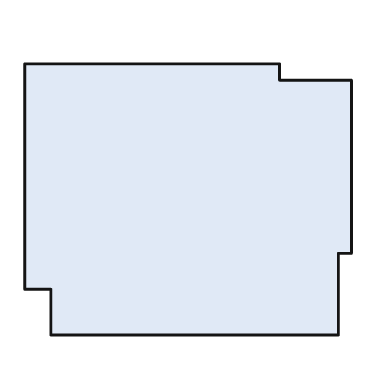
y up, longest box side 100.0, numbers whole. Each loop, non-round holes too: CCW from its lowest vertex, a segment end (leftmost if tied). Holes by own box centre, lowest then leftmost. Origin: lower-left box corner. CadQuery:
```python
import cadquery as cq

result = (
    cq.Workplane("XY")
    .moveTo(8.0, 0.0)
    .lineTo(96.0, 0.0)
    .lineTo(96.0, 25.0)
    .lineTo(100.0, 25.0)
    .lineTo(100.0, 78.0)
    .lineTo(78.0, 78.0)
    .lineTo(78.0, 83.0)
    .lineTo(0.0, 83.0)
    .lineTo(0.0, 14.0)
    .lineTo(8.0, 14.0)
    .close()
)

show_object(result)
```